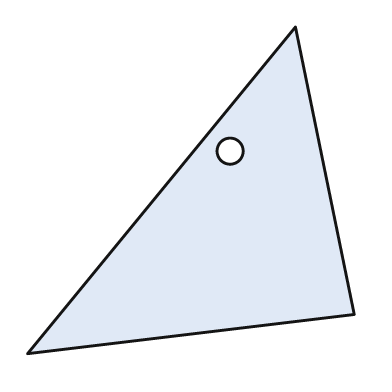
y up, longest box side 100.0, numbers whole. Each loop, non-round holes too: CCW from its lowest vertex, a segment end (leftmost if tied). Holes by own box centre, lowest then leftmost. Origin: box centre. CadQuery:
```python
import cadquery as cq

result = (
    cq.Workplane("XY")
    .moveTo(-50.0, -50.0)
    .lineTo(50.0, -38.0)
    .lineTo(32.0, 50.0)
    .close()
    .moveTo(12.0, 12.0)
    .circle(4.0)
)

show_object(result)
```